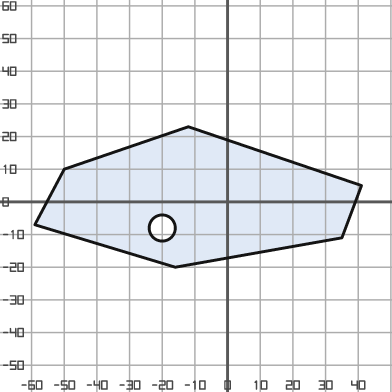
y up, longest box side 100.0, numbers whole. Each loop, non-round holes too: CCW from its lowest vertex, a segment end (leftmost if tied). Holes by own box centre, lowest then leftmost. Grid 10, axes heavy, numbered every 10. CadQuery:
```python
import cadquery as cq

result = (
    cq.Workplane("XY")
    .moveTo(-16.0, -20.0)
    .lineTo(35.0, -11.0)
    .lineTo(41.0, 5.0)
    .lineTo(-12.0, 23.0)
    .lineTo(-50.0, 10.0)
    .lineTo(-59.0, -7.0)
    .close()
    .moveTo(-20.0, -8.0)
    .circle(4.0)
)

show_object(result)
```